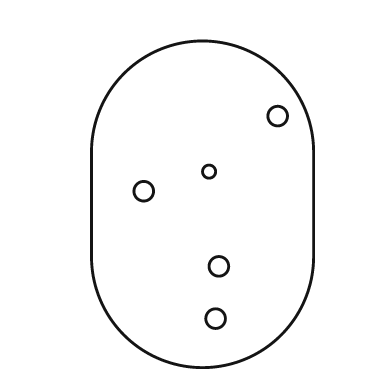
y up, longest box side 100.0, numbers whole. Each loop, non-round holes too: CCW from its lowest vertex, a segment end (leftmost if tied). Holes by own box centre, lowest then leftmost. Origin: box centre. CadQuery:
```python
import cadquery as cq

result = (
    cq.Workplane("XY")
    .moveTo(-34.0, -16.0)
    .threePointArc((0.0, -50.0), (34.0, -16.0))
    .lineTo(34.0, 16.0)
    .threePointArc((0.0, 50.0), (-34.0, 16.0))
    .close()
    .moveTo(4.0, -35.0)
    .circle(3.0)
    .moveTo(5.0, -19.0)
    .circle(3.0)
    .moveTo(-18.0, 4.0)
    .circle(3.0)
    .moveTo(2.0, 10.0)
    .circle(2.0)
    .moveTo(23.0, 27.0)
    .circle(3.0)
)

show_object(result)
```